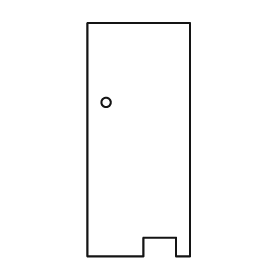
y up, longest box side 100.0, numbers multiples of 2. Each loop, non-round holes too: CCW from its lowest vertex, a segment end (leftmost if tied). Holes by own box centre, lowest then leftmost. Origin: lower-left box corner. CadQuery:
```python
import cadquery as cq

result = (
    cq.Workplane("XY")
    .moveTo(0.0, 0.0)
    .lineTo(24.0, 0.0)
    .lineTo(24.0, 8.0)
    .lineTo(38.0, 8.0)
    .lineTo(38.0, 0.0)
    .lineTo(44.0, 0.0)
    .lineTo(44.0, 100.0)
    .lineTo(0.0, 100.0)
    .close()
    .moveTo(8.0, 66.0)
    .circle(2.0)
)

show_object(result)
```